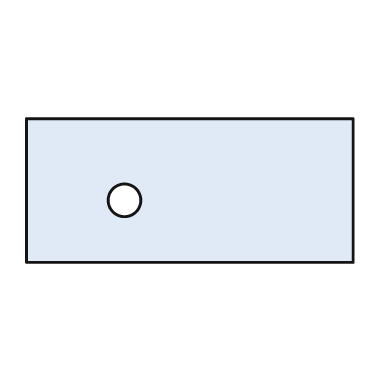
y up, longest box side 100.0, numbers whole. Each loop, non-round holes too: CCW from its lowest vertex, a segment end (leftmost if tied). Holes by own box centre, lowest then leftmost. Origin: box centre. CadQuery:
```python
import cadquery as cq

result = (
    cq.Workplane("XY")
    .moveTo(-50.0, -22.0)
    .lineTo(50.0, -22.0)
    .lineTo(50.0, 22.0)
    .lineTo(-50.0, 22.0)
    .close()
    .moveTo(-20.0, -3.0)
    .circle(5.0)
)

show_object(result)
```